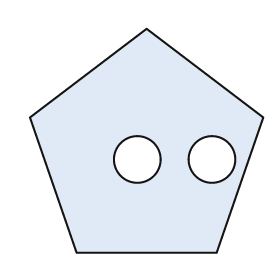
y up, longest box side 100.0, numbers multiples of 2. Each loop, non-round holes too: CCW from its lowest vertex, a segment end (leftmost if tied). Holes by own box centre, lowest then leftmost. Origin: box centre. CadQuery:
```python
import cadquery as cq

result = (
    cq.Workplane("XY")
    .moveTo(-30.0, -48.0)
    .lineTo(30.0, -48.0)
    .lineTo(50.0, 10.0)
    .lineTo(0.0, 48.0)
    .lineTo(-50.0, 10.0)
    .close()
    .moveTo(-4.0, -8.0)
    .circle(10.0)
    .moveTo(28.0, -8.0)
    .circle(10.0)
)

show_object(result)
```